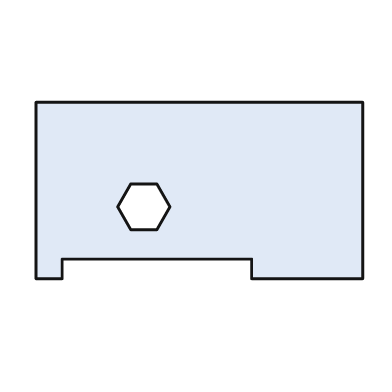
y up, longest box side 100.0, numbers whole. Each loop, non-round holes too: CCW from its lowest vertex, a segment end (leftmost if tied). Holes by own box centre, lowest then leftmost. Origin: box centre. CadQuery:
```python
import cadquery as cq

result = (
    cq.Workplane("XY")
    .moveTo(-50.0, -27.0)
    .lineTo(-42.0, -27.0)
    .lineTo(-42.0, -21.0)
    .lineTo(16.0, -21.0)
    .lineTo(16.0, -27.0)
    .lineTo(50.0, -27.0)
    .lineTo(50.0, 27.0)
    .lineTo(-50.0, 27.0)
    .close()
    .moveTo(-21.0, -12.0)
    .lineTo(-13.0, -12.0)
    .lineTo(-9.0, -5.0)
    .lineTo(-13.0, 2.0)
    .lineTo(-21.0, 2.0)
    .lineTo(-25.0, -5.0)
    .close()
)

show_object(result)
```